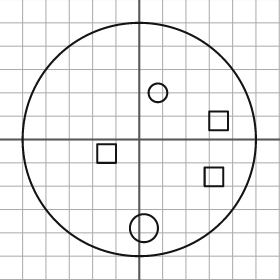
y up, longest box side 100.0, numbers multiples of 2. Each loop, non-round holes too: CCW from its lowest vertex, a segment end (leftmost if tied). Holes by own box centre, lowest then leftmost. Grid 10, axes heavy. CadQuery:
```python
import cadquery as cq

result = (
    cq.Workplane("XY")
    .moveTo(0.0, 0.0)
    .circle(50.0)
    .moveTo(2.0, -38.0)
    .circle(6.0)
    .moveTo(28.0, -20.0)
    .lineTo(36.0, -20.0)
    .lineTo(36.0, -12.0)
    .lineTo(28.0, -12.0)
    .close()
    .moveTo(-18.0, -10.0)
    .lineTo(-10.0, -10.0)
    .lineTo(-10.0, -2.0)
    .lineTo(-18.0, -2.0)
    .close()
    .moveTo(30.0, 4.0)
    .lineTo(38.0, 4.0)
    .lineTo(38.0, 12.0)
    .lineTo(30.0, 12.0)
    .close()
    .moveTo(8.0, 20.0)
    .circle(4.0)
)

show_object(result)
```